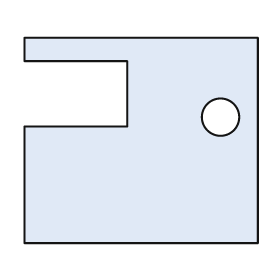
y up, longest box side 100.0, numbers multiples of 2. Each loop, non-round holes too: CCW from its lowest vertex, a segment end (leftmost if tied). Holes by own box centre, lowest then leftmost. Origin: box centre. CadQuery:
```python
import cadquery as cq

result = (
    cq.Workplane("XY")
    .moveTo(-50.0, -44.0)
    .lineTo(50.0, -44.0)
    .lineTo(50.0, 44.0)
    .lineTo(-50.0, 44.0)
    .lineTo(-50.0, 34.0)
    .lineTo(-6.0, 34.0)
    .lineTo(-6.0, 6.0)
    .lineTo(-50.0, 6.0)
    .close()
    .moveTo(34.0, 10.0)
    .circle(8.0)
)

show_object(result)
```